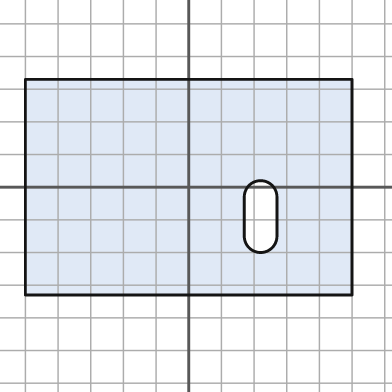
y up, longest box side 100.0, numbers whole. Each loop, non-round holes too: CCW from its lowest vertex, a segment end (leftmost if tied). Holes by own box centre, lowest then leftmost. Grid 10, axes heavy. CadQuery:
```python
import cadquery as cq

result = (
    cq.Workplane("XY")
    .moveTo(-50.0, -33.0)
    .lineTo(50.0, -33.0)
    .lineTo(50.0, 33.0)
    .lineTo(-50.0, 33.0)
    .close()
    .moveTo(17.0, -15.0)
    .threePointArc((22.0, -20.0), (27.0, -15.0))
    .lineTo(27.0, -3.0)
    .threePointArc((22.0, 2.0), (17.0, -3.0))
    .close()
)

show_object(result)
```